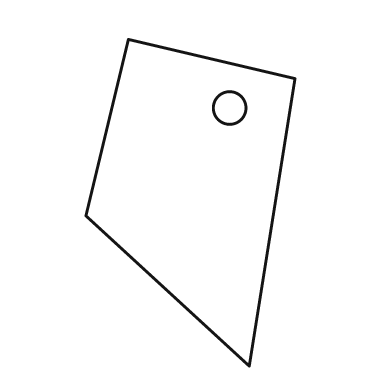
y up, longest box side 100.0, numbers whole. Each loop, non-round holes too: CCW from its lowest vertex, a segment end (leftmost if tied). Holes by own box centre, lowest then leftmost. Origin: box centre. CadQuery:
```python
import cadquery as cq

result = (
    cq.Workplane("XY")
    .moveTo(18.0, -50.0)
    .lineTo(32.0, 38.0)
    .lineTo(-19.0, 50.0)
    .lineTo(-32.0, -4.0)
    .close()
    .moveTo(12.0, 29.0)
    .circle(5.0)
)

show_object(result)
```